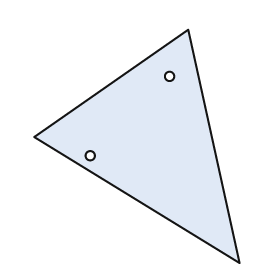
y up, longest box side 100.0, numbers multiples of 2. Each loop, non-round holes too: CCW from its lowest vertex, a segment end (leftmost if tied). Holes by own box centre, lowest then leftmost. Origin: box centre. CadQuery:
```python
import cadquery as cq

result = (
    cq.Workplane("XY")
    .moveTo(44.0, -50.0)
    .lineTo(22.0, 50.0)
    .lineTo(-44.0, 4.0)
    .close()
    .moveTo(-20.0, -4.0)
    .circle(2.0)
    .moveTo(14.0, 30.0)
    .circle(2.0)
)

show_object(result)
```